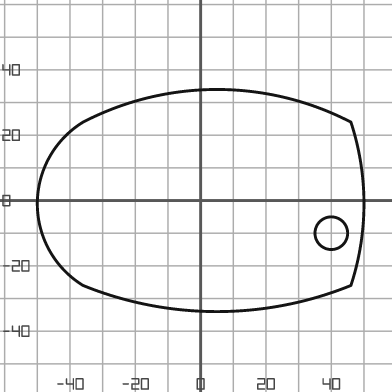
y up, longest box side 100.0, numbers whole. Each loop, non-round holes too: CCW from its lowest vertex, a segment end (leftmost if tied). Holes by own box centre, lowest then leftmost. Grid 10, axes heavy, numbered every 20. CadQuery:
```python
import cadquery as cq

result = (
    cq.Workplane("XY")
    .moveTo(-36.0, -26.0)
    .threePointArc((5.0, -34.0), (46.0, -26.0))
    .threePointArc((50.0, -1.0), (46.0, 24.0))
    .threePointArc((5.0, 34.0), (-36.0, 24.0))
    .threePointArc((-50.0, -1.0), (-36.0, -26.0))
    .close()
    .moveTo(40.0, -10.0)
    .circle(5.0)
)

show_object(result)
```